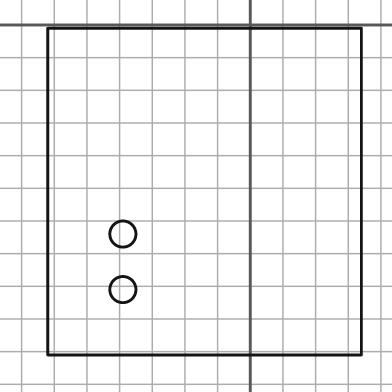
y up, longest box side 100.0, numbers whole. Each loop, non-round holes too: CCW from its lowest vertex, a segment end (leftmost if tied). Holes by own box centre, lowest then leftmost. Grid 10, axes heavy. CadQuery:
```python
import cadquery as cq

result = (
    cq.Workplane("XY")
    .moveTo(-62.0, -101.0)
    .lineTo(34.0, -101.0)
    .lineTo(34.0, -1.0)
    .lineTo(-62.0, -1.0)
    .close()
    .moveTo(-39.0, -81.0)
    .circle(4.0)
    .moveTo(-39.0, -64.0)
    .circle(4.0)
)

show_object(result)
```